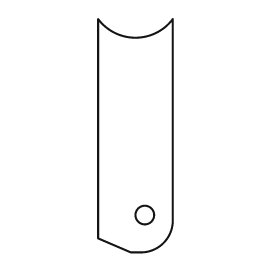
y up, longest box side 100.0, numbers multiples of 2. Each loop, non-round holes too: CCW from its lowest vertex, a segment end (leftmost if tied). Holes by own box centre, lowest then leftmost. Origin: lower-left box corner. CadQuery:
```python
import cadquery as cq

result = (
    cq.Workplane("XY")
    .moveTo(14.0, 0.0)
    .lineTo(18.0, 0.0)
    .threePointArc((28.0, 4.0), (32.0, 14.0))
    .lineTo(32.0, 100.0)
    .threePointArc((16.0, 92.0), (0.0, 100.0))
    .lineTo(0.0, 6.0)
    .close()
    .moveTo(20.0, 16.0)
    .circle(4.0)
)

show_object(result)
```